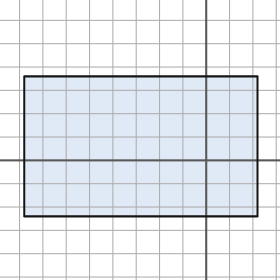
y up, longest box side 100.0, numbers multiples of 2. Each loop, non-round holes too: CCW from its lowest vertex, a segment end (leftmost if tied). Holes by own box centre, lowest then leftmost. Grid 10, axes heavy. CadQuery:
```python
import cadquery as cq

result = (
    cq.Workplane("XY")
    .moveTo(-78.0, -24.0)
    .lineTo(22.0, -24.0)
    .lineTo(22.0, 36.0)
    .lineTo(-78.0, 36.0)
    .close()
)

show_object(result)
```